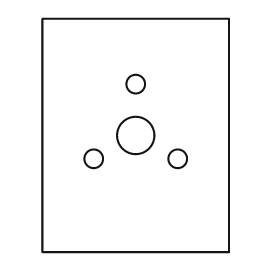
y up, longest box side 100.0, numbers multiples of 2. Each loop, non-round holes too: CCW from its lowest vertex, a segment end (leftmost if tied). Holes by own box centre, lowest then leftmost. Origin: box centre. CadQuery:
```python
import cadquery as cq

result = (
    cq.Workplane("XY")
    .moveTo(-40.0, -50.0)
    .lineTo(40.0, -50.0)
    .lineTo(40.0, 50.0)
    .lineTo(-40.0, 50.0)
    .close()
    .moveTo(-18.0, -10.0)
    .circle(4.0)
    .moveTo(18.0, -10.0)
    .circle(4.0)
    .moveTo(0.0, 0.0)
    .circle(8.0)
    .moveTo(0.0, 22.0)
    .circle(4.0)
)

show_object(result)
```